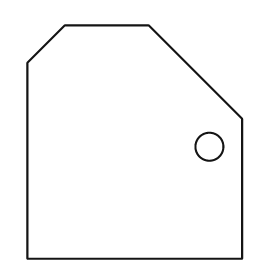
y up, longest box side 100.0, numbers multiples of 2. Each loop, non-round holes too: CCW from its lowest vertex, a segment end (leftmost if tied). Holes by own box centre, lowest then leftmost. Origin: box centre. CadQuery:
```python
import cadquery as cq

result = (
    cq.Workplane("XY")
    .moveTo(-46.0, -50.0)
    .lineTo(46.0, -50.0)
    .lineTo(46.0, 10.0)
    .lineTo(6.0, 50.0)
    .lineTo(-30.0, 50.0)
    .lineTo(-46.0, 34.0)
    .close()
    .moveTo(32.0, -2.0)
    .circle(6.0)
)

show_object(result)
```